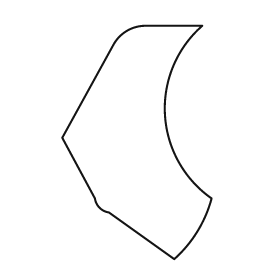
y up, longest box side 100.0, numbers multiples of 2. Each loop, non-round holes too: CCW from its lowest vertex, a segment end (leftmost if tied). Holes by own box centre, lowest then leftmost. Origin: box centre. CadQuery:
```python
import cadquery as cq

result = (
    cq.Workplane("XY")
    .moveTo(16.0, -50.0)
    .threePointArc((26.0, -38.0), (32.0, -24.0))
    .threePointArc((12.0, 12.0), (28.0, 50.0))
    .lineTo(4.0, 50.0)
    .threePointArc((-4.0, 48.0), (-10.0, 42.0))
    .lineTo(-32.0, 2.0)
    .lineTo(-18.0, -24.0)
    .threePointArc((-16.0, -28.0), (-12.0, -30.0))
    .close()
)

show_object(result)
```